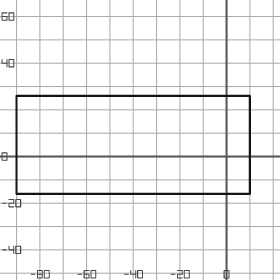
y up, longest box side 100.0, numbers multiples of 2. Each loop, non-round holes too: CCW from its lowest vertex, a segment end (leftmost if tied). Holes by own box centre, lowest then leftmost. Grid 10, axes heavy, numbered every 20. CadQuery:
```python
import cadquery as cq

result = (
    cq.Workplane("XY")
    .moveTo(-90.0, -16.0)
    .lineTo(10.0, -16.0)
    .lineTo(10.0, 26.0)
    .lineTo(-90.0, 26.0)
    .close()
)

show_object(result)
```